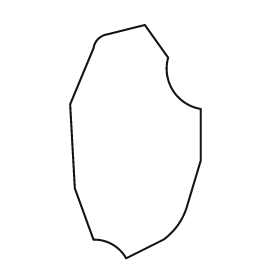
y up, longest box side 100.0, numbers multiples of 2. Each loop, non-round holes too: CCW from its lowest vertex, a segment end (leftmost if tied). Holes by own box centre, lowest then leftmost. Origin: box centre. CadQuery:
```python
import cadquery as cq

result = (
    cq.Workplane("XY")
    .moveTo(-4.0, -50.0)
    .lineTo(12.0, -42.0)
    .threePointArc((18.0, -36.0), (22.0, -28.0))
    .lineTo(28.0, -8.0)
    .lineTo(28.0, 14.0)
    .threePointArc((16.0, 22.0), (14.0, 36.0))
    .lineTo(4.0, 50.0)
    .lineTo(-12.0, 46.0)
    .threePointArc((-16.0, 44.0), (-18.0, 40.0))
    .lineTo(-28.0, 16.0)
    .lineTo(-26.0, -20.0)
    .lineTo(-18.0, -42.0)
    .threePointArc((-10.0, -44.0), (-4.0, -50.0))
    .close()
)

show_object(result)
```